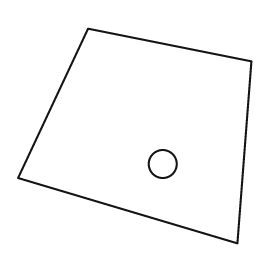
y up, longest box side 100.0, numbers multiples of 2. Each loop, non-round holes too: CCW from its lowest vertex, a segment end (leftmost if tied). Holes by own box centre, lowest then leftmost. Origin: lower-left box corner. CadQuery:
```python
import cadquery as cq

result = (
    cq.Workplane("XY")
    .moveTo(94.0, 0.0)
    .lineTo(100.0, 78.0)
    .lineTo(30.0, 92.0)
    .lineTo(0.0, 28.0)
    .close()
    .moveTo(62.0, 34.0)
    .circle(6.0)
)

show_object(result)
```